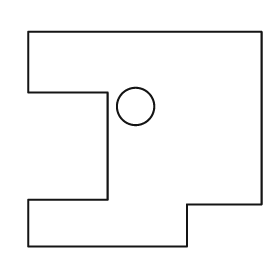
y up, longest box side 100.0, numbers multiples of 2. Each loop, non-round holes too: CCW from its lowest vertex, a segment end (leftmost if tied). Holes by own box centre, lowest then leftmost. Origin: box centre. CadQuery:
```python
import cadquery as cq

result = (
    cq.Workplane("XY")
    .moveTo(-50.0, -46.0)
    .lineTo(18.0, -46.0)
    .lineTo(18.0, -28.0)
    .lineTo(50.0, -28.0)
    .lineTo(50.0, 46.0)
    .lineTo(-50.0, 46.0)
    .lineTo(-50.0, 20.0)
    .lineTo(-16.0, 20.0)
    .lineTo(-16.0, -26.0)
    .lineTo(-50.0, -26.0)
    .close()
    .moveTo(-4.0, 14.0)
    .circle(8.0)
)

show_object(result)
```